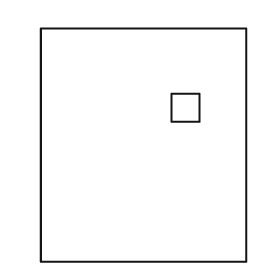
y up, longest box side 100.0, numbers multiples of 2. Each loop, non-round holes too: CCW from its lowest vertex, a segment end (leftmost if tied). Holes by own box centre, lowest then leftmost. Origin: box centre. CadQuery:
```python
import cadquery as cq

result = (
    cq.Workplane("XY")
    .moveTo(-44.0, -50.0)
    .lineTo(44.0, -50.0)
    .lineTo(44.0, 50.0)
    .lineTo(-44.0, 50.0)
    .close()
    .moveTo(12.0, 10.0)
    .lineTo(24.0, 10.0)
    .lineTo(24.0, 22.0)
    .lineTo(12.0, 22.0)
    .close()
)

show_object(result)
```